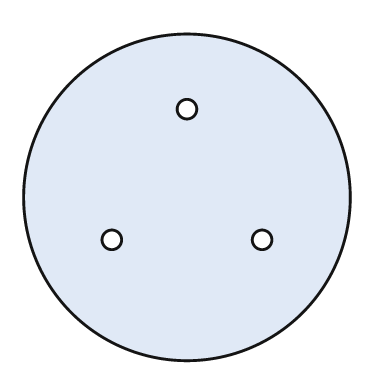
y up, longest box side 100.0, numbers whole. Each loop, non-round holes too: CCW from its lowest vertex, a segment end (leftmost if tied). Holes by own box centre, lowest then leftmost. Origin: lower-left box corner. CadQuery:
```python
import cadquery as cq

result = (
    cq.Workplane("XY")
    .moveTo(50.0, 50.0)
    .circle(50.0)
    .moveTo(27.0, 37.0)
    .circle(3.0)
    .moveTo(73.0, 37.0)
    .circle(3.0)
    .moveTo(50.0, 77.0)
    .circle(3.0)
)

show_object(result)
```